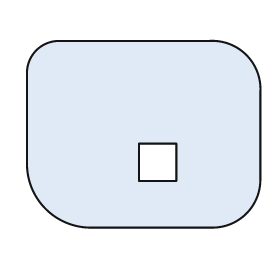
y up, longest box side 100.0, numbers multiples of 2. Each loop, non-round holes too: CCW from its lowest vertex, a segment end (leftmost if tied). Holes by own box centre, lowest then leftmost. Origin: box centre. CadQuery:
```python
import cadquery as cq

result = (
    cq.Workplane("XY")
    .moveTo(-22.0, -40.0)
    .lineTo(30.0, -40.0)
    .threePointArc((44.0, -34.0), (50.0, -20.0))
    .lineTo(50.0, 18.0)
    .threePointArc((44.0, 34.0), (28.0, 40.0))
    .lineTo(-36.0, 40.0)
    .threePointArc((-46.0, 36.0), (-50.0, 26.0))
    .lineTo(-50.0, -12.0)
    .threePointArc((-42.0, -32.0), (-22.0, -40.0))
    .close()
    .moveTo(-2.0, -20.0)
    .lineTo(14.0, -20.0)
    .lineTo(14.0, -4.0)
    .lineTo(-2.0, -4.0)
    .close()
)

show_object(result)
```